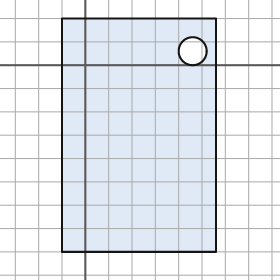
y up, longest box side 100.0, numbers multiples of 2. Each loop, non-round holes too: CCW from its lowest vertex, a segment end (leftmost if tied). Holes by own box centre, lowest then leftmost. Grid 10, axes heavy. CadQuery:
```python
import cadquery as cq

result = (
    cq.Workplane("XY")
    .moveTo(-10.0, -80.0)
    .lineTo(56.0, -80.0)
    .lineTo(56.0, 20.0)
    .lineTo(-10.0, 20.0)
    .close()
    .moveTo(46.0, 6.0)
    .circle(6.0)
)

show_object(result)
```